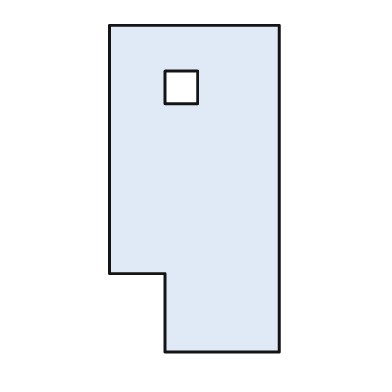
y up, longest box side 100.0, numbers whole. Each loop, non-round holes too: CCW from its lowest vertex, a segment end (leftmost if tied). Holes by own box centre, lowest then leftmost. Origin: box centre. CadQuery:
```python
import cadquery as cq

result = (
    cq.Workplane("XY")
    .moveTo(-9.0, -50.0)
    .lineTo(26.0, -50.0)
    .lineTo(26.0, 50.0)
    .lineTo(-26.0, 50.0)
    .lineTo(-26.0, -26.0)
    .lineTo(-9.0, -26.0)
    .close()
    .moveTo(-9.0, 26.0)
    .lineTo(1.0, 26.0)
    .lineTo(1.0, 36.0)
    .lineTo(-9.0, 36.0)
    .close()
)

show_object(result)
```